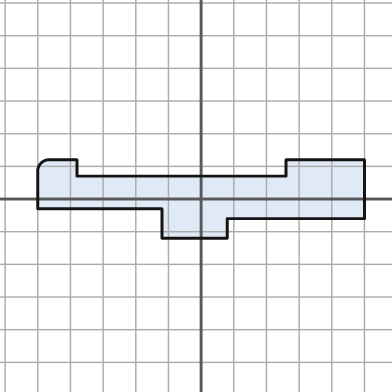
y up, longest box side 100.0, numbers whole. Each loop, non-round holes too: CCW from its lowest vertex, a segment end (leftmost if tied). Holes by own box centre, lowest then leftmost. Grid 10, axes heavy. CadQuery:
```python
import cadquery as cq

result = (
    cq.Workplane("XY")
    .moveTo(-12.0, -12.0)
    .lineTo(8.0, -12.0)
    .lineTo(8.0, -6.0)
    .lineTo(50.0, -6.0)
    .lineTo(50.0, 12.0)
    .lineTo(26.0, 12.0)
    .lineTo(26.0, 7.0)
    .lineTo(-38.0, 7.0)
    .lineTo(-38.0, 12.0)
    .lineTo(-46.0, 12.0)
    .threePointArc((-49.0, 11.0), (-50.0, 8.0))
    .lineTo(-50.0, -3.0)
    .lineTo(-12.0, -3.0)
    .close()
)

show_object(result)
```